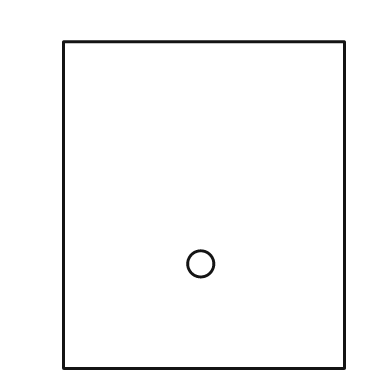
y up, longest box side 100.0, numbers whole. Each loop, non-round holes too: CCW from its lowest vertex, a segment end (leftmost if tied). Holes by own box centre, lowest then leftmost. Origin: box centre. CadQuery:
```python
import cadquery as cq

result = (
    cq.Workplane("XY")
    .moveTo(-43.0, -50.0)
    .lineTo(43.0, -50.0)
    .lineTo(43.0, 50.0)
    .lineTo(-43.0, 50.0)
    .close()
    .moveTo(-1.0, -18.0)
    .circle(4.0)
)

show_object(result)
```